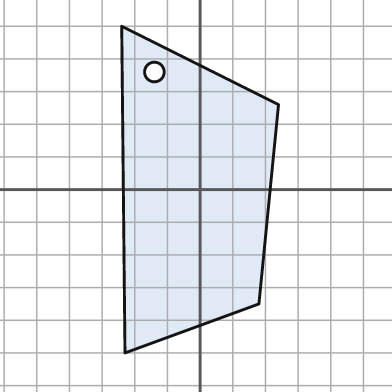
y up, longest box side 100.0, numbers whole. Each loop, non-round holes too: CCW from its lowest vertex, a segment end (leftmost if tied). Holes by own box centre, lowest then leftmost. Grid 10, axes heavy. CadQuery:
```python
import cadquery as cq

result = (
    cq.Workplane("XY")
    .moveTo(-23.0, -50.0)
    .lineTo(18.0, -35.0)
    .lineTo(24.0, 26.0)
    .lineTo(-24.0, 50.0)
    .close()
    .moveTo(-14.0, 36.0)
    .circle(3.0)
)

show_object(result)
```